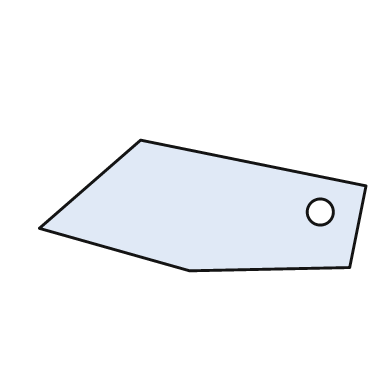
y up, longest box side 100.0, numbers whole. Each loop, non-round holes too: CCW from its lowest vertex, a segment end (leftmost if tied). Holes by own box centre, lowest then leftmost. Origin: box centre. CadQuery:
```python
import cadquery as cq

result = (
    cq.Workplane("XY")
    .moveTo(-4.0, -20.0)
    .lineTo(45.0, -19.0)
    .lineTo(50.0, 6.0)
    .lineTo(-19.0, 20.0)
    .lineTo(-50.0, -7.0)
    .close()
    .moveTo(36.0, -2.0)
    .circle(4.0)
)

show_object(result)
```